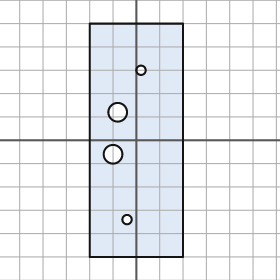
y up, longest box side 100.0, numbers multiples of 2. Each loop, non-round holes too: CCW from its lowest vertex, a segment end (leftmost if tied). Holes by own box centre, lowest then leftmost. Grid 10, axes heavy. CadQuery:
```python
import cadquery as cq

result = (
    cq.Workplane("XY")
    .moveTo(-20.0, -50.0)
    .lineTo(20.0, -50.0)
    .lineTo(20.0, 50.0)
    .lineTo(-20.0, 50.0)
    .close()
    .moveTo(-4.0, -34.0)
    .circle(2.0)
    .moveTo(-10.0, -6.0)
    .circle(4.0)
    .moveTo(-8.0, 12.0)
    .circle(4.0)
    .moveTo(2.0, 30.0)
    .circle(2.0)
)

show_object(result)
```